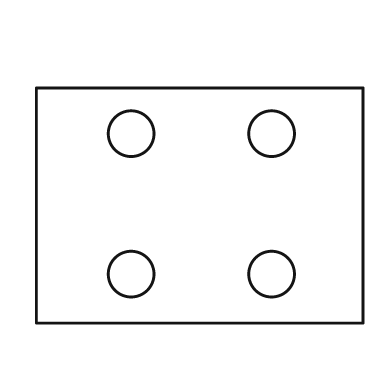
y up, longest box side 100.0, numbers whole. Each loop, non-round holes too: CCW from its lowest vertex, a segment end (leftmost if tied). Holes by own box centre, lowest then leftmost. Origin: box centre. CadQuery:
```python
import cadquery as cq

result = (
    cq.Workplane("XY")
    .moveTo(-50.0, -36.0)
    .lineTo(50.0, -36.0)
    .lineTo(50.0, 36.0)
    .lineTo(-50.0, 36.0)
    .close()
    .moveTo(-21.0, -21.0)
    .circle(7.0)
    .moveTo(22.0, -21.0)
    .circle(7.0)
    .moveTo(-21.0, 22.0)
    .circle(7.0)
    .moveTo(22.0, 22.0)
    .circle(7.0)
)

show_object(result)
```